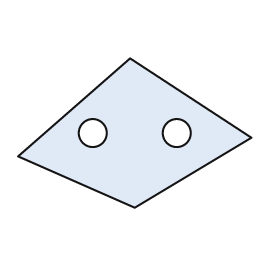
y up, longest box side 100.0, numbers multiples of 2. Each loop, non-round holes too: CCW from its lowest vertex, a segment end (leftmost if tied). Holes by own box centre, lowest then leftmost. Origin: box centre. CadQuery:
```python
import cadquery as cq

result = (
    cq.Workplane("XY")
    .moveTo(0.0, -32.0)
    .lineTo(50.0, -2.0)
    .lineTo(-2.0, 32.0)
    .lineTo(-50.0, -10.0)
    .close()
    .moveTo(-18.0, 0.0)
    .circle(6.0)
    .moveTo(18.0, 0.0)
    .circle(6.0)
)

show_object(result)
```